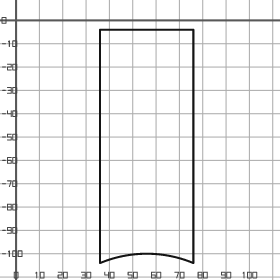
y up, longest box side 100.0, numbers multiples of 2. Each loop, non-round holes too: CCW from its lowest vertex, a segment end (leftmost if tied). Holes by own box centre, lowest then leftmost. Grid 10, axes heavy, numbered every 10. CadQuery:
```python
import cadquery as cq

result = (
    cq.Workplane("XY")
    .moveTo(36.0, -104.0)
    .threePointArc((56.0, -100.0), (76.0, -104.0))
    .lineTo(76.0, -4.0)
    .lineTo(36.0, -4.0)
    .close()
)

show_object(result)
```